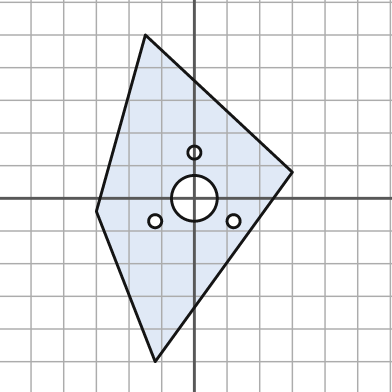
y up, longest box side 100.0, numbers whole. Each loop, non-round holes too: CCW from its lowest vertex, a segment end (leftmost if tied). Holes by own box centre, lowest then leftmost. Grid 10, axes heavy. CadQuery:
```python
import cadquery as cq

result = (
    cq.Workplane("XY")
    .moveTo(-12.0, -50.0)
    .lineTo(30.0, 8.0)
    .lineTo(-15.0, 50.0)
    .lineTo(-30.0, -4.0)
    .close()
    .moveTo(-12.0, -7.0)
    .circle(2.0)
    .moveTo(12.0, -7.0)
    .circle(2.0)
    .moveTo(0.0, 0.0)
    .circle(7.0)
    .moveTo(0.0, 14.0)
    .circle(2.0)
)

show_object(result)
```